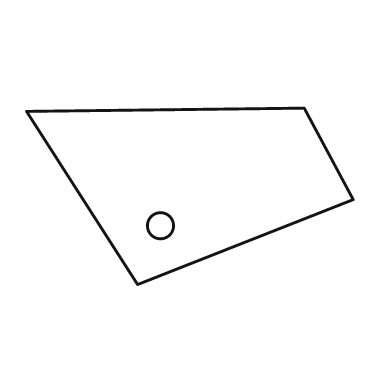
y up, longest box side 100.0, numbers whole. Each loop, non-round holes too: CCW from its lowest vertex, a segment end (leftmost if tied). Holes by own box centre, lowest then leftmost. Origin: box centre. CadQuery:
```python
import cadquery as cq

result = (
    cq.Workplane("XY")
    .moveTo(-16.0, -27.0)
    .lineTo(50.0, -1.0)
    .lineTo(35.0, 27.0)
    .lineTo(-50.0, 26.0)
    .close()
    .moveTo(-9.0, -9.0)
    .circle(4.0)
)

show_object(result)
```